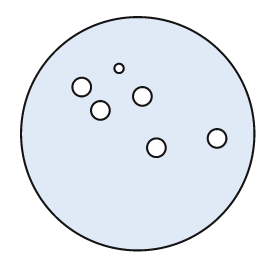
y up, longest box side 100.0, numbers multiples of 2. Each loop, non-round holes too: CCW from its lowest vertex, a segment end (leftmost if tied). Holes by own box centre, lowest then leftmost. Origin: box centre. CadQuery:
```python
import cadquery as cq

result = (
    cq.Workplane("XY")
    .moveTo(0.0, 0.0)
    .circle(50.0)
    .moveTo(8.0, -6.0)
    .circle(4.0)
    .moveTo(34.0, -2.0)
    .circle(4.0)
    .moveTo(-16.0, 10.0)
    .circle(4.0)
    .moveTo(2.0, 16.0)
    .circle(4.0)
    .moveTo(-24.0, 20.0)
    .circle(4.0)
    .moveTo(-8.0, 28.0)
    .circle(2.0)
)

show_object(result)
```